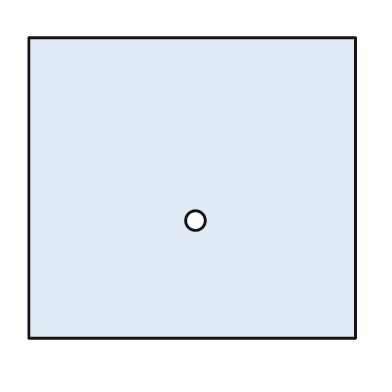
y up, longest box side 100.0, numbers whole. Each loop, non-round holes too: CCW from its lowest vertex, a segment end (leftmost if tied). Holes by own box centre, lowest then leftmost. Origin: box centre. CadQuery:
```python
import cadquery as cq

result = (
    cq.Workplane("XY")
    .moveTo(-50.0, -46.0)
    .lineTo(50.0, -46.0)
    .lineTo(50.0, 46.0)
    .lineTo(-50.0, 46.0)
    .close()
    .moveTo(1.0, -10.0)
    .circle(3.0)
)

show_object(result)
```